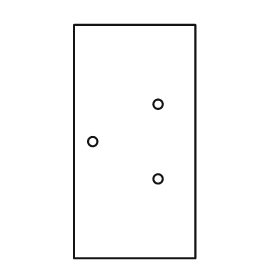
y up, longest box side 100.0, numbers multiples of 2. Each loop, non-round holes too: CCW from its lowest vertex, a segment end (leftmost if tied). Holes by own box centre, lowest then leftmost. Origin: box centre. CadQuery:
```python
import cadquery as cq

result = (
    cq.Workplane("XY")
    .moveTo(-26.0, -50.0)
    .lineTo(26.0, -50.0)
    .lineTo(26.0, 50.0)
    .lineTo(-26.0, 50.0)
    .close()
    .moveTo(10.0, -16.0)
    .circle(2.0)
    .moveTo(-18.0, 0.0)
    .circle(2.0)
    .moveTo(10.0, 16.0)
    .circle(2.0)
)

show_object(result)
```